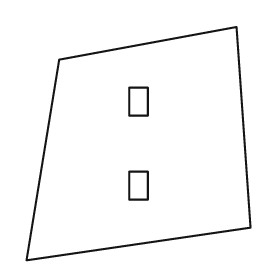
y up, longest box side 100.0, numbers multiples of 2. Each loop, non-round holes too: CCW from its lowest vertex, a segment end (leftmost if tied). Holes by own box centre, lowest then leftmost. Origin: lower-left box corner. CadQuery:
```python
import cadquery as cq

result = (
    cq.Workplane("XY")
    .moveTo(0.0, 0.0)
    .lineTo(96.0, 14.0)
    .lineTo(90.0, 100.0)
    .lineTo(14.0, 86.0)
    .close()
    .moveTo(44.0, 26.0)
    .lineTo(52.0, 26.0)
    .lineTo(52.0, 38.0)
    .lineTo(44.0, 38.0)
    .close()
    .moveTo(44.0, 62.0)
    .lineTo(52.0, 62.0)
    .lineTo(52.0, 74.0)
    .lineTo(44.0, 74.0)
    .close()
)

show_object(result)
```